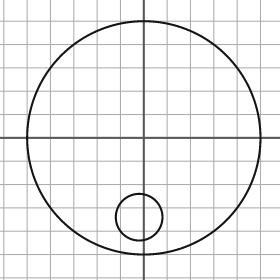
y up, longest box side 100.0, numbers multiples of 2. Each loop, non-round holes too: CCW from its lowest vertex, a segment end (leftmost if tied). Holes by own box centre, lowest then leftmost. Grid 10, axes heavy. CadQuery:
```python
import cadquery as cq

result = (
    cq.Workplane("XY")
    .moveTo(0.0, 0.0)
    .circle(50.0)
    .moveTo(-2.0, -34.0)
    .circle(10.0)
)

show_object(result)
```